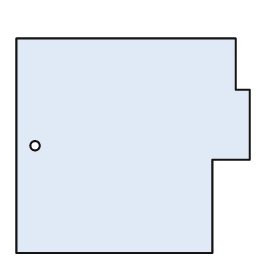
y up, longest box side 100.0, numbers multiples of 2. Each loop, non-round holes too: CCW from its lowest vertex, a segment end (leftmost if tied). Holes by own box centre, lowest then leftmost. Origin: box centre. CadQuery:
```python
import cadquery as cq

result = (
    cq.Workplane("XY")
    .moveTo(-50.0, -46.0)
    .lineTo(34.0, -46.0)
    .lineTo(34.0, -6.0)
    .lineTo(50.0, -6.0)
    .lineTo(50.0, 24.0)
    .lineTo(44.0, 24.0)
    .lineTo(44.0, 46.0)
    .lineTo(-50.0, 46.0)
    .close()
    .moveTo(-42.0, 0.0)
    .circle(2.0)
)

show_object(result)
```